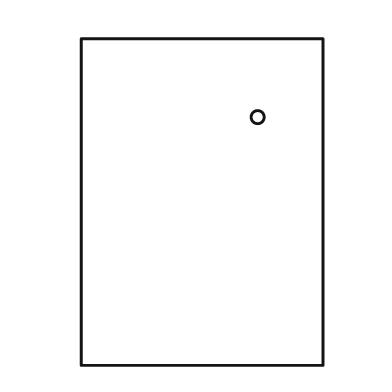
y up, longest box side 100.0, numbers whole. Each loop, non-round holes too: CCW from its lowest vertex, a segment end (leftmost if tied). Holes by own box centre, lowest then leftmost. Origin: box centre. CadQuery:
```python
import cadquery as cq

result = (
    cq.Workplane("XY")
    .moveTo(-37.0, -50.0)
    .lineTo(37.0, -50.0)
    .lineTo(37.0, 50.0)
    .lineTo(-37.0, 50.0)
    .close()
    .moveTo(17.0, 26.0)
    .circle(2.0)
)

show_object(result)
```